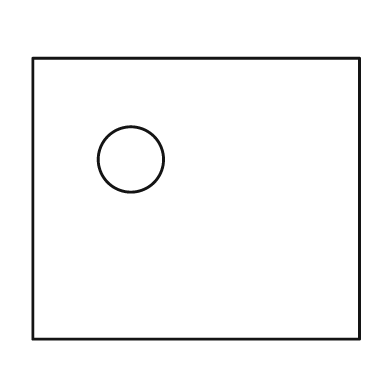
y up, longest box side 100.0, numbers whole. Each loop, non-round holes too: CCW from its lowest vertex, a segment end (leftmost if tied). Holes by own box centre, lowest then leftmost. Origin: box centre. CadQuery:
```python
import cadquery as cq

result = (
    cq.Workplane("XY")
    .moveTo(-50.0, -43.0)
    .lineTo(50.0, -43.0)
    .lineTo(50.0, 43.0)
    .lineTo(-50.0, 43.0)
    .close()
    .moveTo(-20.0, 12.0)
    .circle(10.0)
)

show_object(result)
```